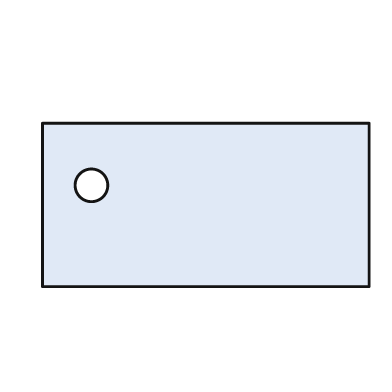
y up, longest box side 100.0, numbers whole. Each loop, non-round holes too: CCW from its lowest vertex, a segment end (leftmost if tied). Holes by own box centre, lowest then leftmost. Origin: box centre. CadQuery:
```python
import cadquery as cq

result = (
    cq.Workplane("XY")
    .moveTo(-50.0, -25.0)
    .lineTo(50.0, -25.0)
    .lineTo(50.0, 25.0)
    .lineTo(-50.0, 25.0)
    .close()
    .moveTo(-35.0, 6.0)
    .circle(5.0)
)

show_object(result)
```